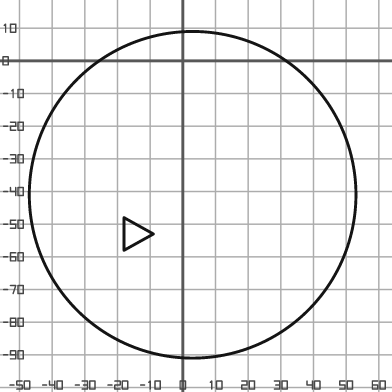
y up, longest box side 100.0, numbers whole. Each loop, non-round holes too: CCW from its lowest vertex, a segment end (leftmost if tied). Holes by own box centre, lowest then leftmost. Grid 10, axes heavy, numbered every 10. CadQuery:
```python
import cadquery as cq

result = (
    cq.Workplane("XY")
    .moveTo(3.0, -41.0)
    .circle(50.0)
    .moveTo(-18.0, -58.0)
    .lineTo(-9.0, -53.0)
    .lineTo(-18.0, -48.0)
    .close()
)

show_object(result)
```